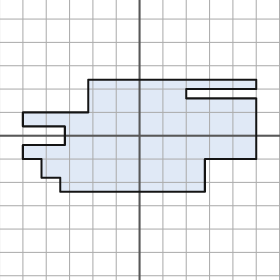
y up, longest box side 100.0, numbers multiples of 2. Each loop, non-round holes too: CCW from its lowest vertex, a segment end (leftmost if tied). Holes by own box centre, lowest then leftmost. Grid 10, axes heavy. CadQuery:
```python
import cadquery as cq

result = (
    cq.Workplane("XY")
    .moveTo(-34.0, -24.0)
    .lineTo(28.0, -24.0)
    .lineTo(28.0, -10.0)
    .lineTo(50.0, -10.0)
    .lineTo(50.0, 16.0)
    .lineTo(20.0, 16.0)
    .lineTo(20.0, 20.0)
    .lineTo(50.0, 20.0)
    .lineTo(50.0, 24.0)
    .lineTo(-22.0, 24.0)
    .lineTo(-22.0, 10.0)
    .lineTo(-50.0, 10.0)
    .lineTo(-50.0, 4.0)
    .lineTo(-32.0, 4.0)
    .lineTo(-32.0, -4.0)
    .lineTo(-50.0, -4.0)
    .lineTo(-50.0, -10.0)
    .lineTo(-42.0, -10.0)
    .lineTo(-42.0, -18.0)
    .lineTo(-34.0, -18.0)
    .close()
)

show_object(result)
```